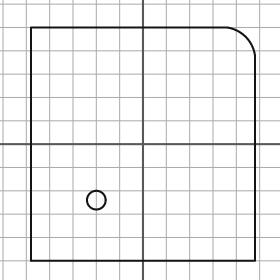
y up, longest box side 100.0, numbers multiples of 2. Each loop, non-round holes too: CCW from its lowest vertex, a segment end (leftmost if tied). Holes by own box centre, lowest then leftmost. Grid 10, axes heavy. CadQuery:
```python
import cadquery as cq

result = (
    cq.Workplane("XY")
    .moveTo(-48.0, -50.0)
    .lineTo(48.0, -50.0)
    .lineTo(48.0, 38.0)
    .threePointArc((44.0, 46.0), (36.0, 50.0))
    .lineTo(-48.0, 50.0)
    .close()
    .moveTo(-20.0, -24.0)
    .circle(4.0)
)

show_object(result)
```